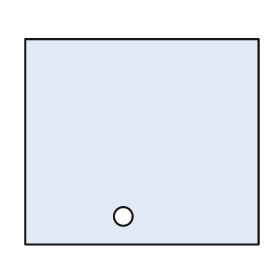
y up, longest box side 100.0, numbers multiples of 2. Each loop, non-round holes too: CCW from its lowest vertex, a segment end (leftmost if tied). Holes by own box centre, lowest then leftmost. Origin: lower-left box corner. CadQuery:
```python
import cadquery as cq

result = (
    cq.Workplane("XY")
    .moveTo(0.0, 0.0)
    .lineTo(100.0, 0.0)
    .lineTo(100.0, 88.0)
    .lineTo(0.0, 88.0)
    .close()
    .moveTo(42.0, 12.0)
    .circle(4.0)
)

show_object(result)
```